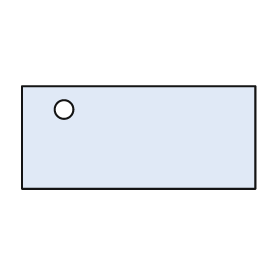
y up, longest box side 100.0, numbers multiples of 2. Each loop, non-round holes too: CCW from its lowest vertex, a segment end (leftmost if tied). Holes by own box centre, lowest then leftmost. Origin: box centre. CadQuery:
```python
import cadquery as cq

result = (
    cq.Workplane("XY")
    .moveTo(-50.0, -22.0)
    .lineTo(50.0, -22.0)
    .lineTo(50.0, 22.0)
    .lineTo(-50.0, 22.0)
    .close()
    .moveTo(-32.0, 12.0)
    .circle(4.0)
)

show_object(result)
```